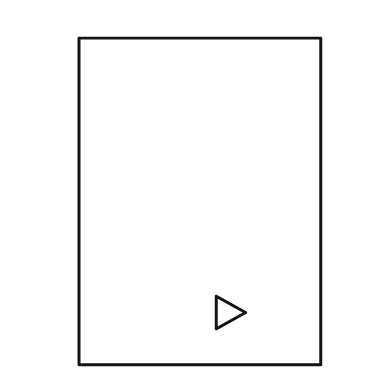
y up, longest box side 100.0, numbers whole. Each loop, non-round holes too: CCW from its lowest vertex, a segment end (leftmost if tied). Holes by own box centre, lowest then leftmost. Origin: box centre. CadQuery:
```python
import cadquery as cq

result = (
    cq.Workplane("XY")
    .moveTo(-37.0, -50.0)
    .lineTo(37.0, -50.0)
    .lineTo(37.0, 50.0)
    .lineTo(-37.0, 50.0)
    .close()
    .moveTo(5.0, -39.0)
    .lineTo(14.0, -34.0)
    .lineTo(5.0, -29.0)
    .close()
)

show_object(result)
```